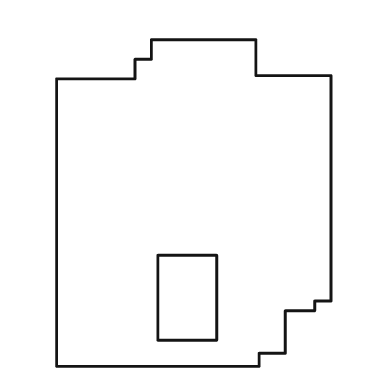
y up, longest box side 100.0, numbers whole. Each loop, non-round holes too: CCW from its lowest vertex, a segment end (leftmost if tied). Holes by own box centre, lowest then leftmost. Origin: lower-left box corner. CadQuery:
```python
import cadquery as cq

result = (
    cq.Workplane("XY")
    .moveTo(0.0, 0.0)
    .lineTo(62.0, 0.0)
    .lineTo(62.0, 4.0)
    .lineTo(70.0, 4.0)
    .lineTo(70.0, 17.0)
    .lineTo(79.0, 17.0)
    .lineTo(79.0, 20.0)
    .lineTo(84.0, 20.0)
    .lineTo(84.0, 89.0)
    .lineTo(61.0, 89.0)
    .lineTo(61.0, 100.0)
    .lineTo(29.0, 100.0)
    .lineTo(29.0, 94.0)
    .lineTo(24.0, 94.0)
    .lineTo(24.0, 88.0)
    .lineTo(0.0, 88.0)
    .close()
    .moveTo(31.0, 8.0)
    .lineTo(49.0, 8.0)
    .lineTo(49.0, 34.0)
    .lineTo(31.0, 34.0)
    .close()
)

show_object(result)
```